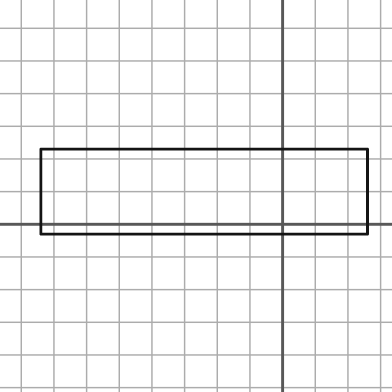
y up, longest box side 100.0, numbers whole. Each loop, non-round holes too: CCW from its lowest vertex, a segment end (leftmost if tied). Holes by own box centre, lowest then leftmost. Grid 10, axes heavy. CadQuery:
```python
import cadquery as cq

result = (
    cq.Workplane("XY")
    .moveTo(-74.0, -3.0)
    .lineTo(26.0, -3.0)
    .lineTo(26.0, 23.0)
    .lineTo(-74.0, 23.0)
    .close()
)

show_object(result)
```